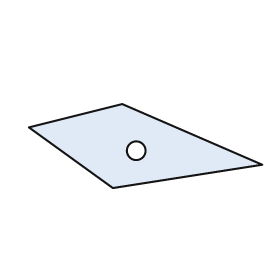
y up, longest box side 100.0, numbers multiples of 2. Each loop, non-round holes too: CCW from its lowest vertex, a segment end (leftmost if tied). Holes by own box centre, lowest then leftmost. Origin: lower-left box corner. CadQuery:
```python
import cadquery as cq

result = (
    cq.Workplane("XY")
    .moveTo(36.0, 0.0)
    .lineTo(100.0, 10.0)
    .lineTo(40.0, 36.0)
    .lineTo(0.0, 26.0)
    .close()
    .moveTo(46.0, 16.0)
    .circle(4.0)
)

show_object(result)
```